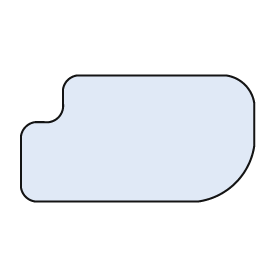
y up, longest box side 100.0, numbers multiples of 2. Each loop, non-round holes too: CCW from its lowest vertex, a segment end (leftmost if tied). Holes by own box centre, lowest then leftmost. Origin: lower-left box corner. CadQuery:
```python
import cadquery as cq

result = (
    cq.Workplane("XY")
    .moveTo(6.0, 0.0)
    .lineTo(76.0, 0.0)
    .threePointArc((92.0, 8.0), (100.0, 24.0))
    .lineTo(100.0, 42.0)
    .threePointArc((96.0, 50.0), (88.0, 54.0))
    .lineTo(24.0, 54.0)
    .threePointArc((20.0, 52.0), (18.0, 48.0))
    .lineTo(18.0, 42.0)
    .threePointArc((16.0, 36.0), (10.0, 34.0))
    .lineTo(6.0, 34.0)
    .threePointArc((2.0, 32.0), (0.0, 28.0))
    .lineTo(0.0, 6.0)
    .threePointArc((2.0, 2.0), (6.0, 0.0))
    .close()
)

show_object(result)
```